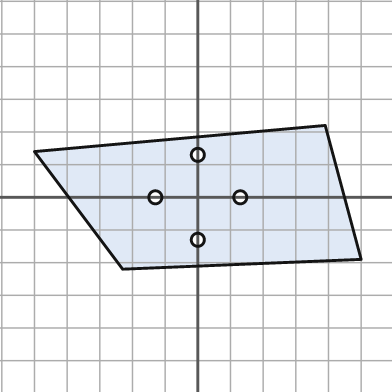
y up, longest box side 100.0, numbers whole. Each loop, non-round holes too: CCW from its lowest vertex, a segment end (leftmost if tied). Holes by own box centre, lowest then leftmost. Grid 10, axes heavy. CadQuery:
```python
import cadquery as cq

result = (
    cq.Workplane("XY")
    .moveTo(-23.0, -22.0)
    .lineTo(50.0, -19.0)
    .lineTo(39.0, 22.0)
    .lineTo(-50.0, 14.0)
    .close()
    .moveTo(0.0, -13.0)
    .circle(2.0)
    .moveTo(-13.0, 0.0)
    .circle(2.0)
    .moveTo(13.0, 0.0)
    .circle(2.0)
    .moveTo(0.0, 13.0)
    .circle(2.0)
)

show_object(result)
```